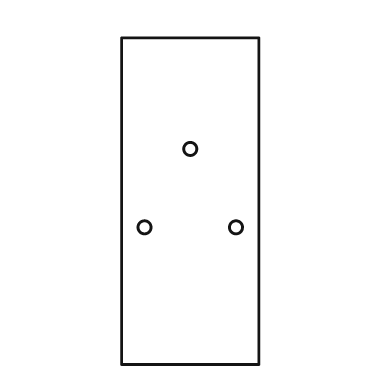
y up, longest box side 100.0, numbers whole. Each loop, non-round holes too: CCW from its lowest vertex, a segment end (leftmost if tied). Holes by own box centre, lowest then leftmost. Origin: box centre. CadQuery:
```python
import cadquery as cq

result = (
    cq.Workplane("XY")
    .moveTo(-21.0, -50.0)
    .lineTo(21.0, -50.0)
    .lineTo(21.0, 50.0)
    .lineTo(-21.0, 50.0)
    .close()
    .moveTo(-14.0, -8.0)
    .circle(2.0)
    .moveTo(14.0, -8.0)
    .circle(2.0)
    .moveTo(0.0, 16.0)
    .circle(2.0)
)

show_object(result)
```